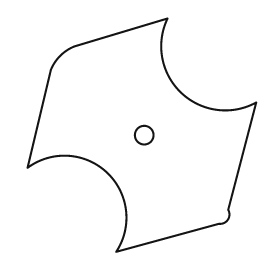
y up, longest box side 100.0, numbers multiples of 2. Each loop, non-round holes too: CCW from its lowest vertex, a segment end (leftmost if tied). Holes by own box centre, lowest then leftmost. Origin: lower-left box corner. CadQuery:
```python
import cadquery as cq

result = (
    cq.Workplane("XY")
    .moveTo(38.0, 0.0)
    .lineTo(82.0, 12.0)
    .threePointArc((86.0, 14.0), (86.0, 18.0))
    .lineTo(98.0, 64.0)
    .threePointArc((66.0, 68.0), (60.0, 100.0))
    .lineTo(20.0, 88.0)
    .threePointArc((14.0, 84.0), (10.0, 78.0))
    .lineTo(0.0, 36.0)
    .threePointArc((34.0, 34.0), (38.0, 0.0))
    .close()
    .moveTo(50.0, 50.0)
    .circle(4.0)
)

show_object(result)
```